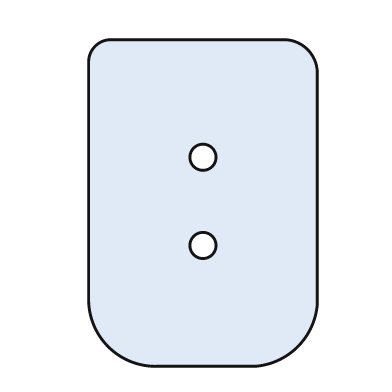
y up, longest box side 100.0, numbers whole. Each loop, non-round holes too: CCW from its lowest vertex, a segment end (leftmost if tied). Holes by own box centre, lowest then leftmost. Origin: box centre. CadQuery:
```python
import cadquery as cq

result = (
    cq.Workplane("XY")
    .moveTo(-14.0, -50.0)
    .lineTo(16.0, -50.0)
    .threePointArc((29.0, -44.0), (35.0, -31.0))
    .lineTo(35.0, 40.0)
    .threePointArc((32.0, 47.0), (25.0, 50.0))
    .lineTo(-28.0, 50.0)
    .threePointArc((-33.0, 48.0), (-35.0, 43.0))
    .lineTo(-35.0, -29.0)
    .threePointArc((-29.0, -44.0), (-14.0, -50.0))
    .close()
    .moveTo(0.0, -13.0)
    .circle(4.0)
    .moveTo(0.0, 14.0)
    .circle(4.0)
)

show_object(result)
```